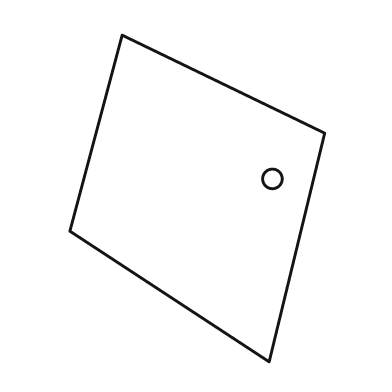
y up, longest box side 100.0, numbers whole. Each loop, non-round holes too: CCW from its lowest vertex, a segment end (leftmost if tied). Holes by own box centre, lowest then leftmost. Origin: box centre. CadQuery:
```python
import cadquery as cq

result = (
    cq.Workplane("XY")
    .moveTo(22.0, -50.0)
    .lineTo(39.0, 20.0)
    .lineTo(-23.0, 50.0)
    .lineTo(-39.0, -10.0)
    .close()
    .moveTo(23.0, 6.0)
    .circle(3.0)
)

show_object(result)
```